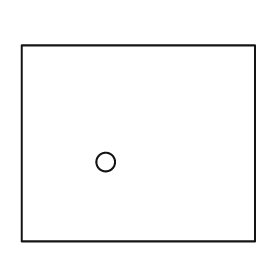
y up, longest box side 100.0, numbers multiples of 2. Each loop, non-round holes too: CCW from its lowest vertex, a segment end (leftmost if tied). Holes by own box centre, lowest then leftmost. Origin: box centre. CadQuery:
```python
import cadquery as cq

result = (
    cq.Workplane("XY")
    .moveTo(-50.0, -42.0)
    .lineTo(50.0, -42.0)
    .lineTo(50.0, 42.0)
    .lineTo(-50.0, 42.0)
    .close()
    .moveTo(-14.0, -8.0)
    .circle(4.0)
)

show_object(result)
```